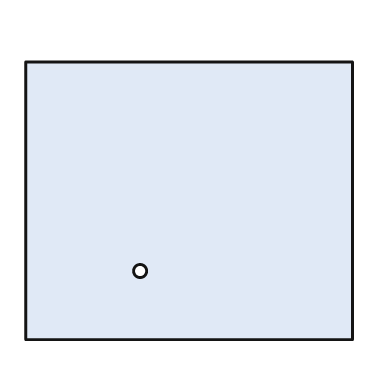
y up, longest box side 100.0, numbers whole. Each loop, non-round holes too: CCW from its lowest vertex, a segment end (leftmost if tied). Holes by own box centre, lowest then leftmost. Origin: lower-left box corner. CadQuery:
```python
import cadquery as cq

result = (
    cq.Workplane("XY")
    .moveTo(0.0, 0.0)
    .lineTo(100.0, 0.0)
    .lineTo(100.0, 85.0)
    .lineTo(0.0, 85.0)
    .close()
    .moveTo(35.0, 21.0)
    .circle(2.0)
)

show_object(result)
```